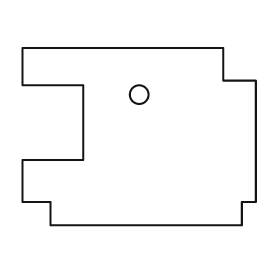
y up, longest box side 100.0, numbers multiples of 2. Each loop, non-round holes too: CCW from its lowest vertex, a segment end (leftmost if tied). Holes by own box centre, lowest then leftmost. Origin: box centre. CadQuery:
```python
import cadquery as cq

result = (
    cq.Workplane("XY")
    .moveTo(-38.0, -38.0)
    .lineTo(44.0, -38.0)
    .lineTo(44.0, -28.0)
    .lineTo(50.0, -28.0)
    .lineTo(50.0, 24.0)
    .lineTo(36.0, 24.0)
    .lineTo(36.0, 38.0)
    .lineTo(-50.0, 38.0)
    .lineTo(-50.0, 22.0)
    .lineTo(-24.0, 22.0)
    .lineTo(-24.0, -10.0)
    .lineTo(-50.0, -10.0)
    .lineTo(-50.0, -28.0)
    .lineTo(-38.0, -28.0)
    .close()
    .moveTo(0.0, 18.0)
    .circle(4.0)
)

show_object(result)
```